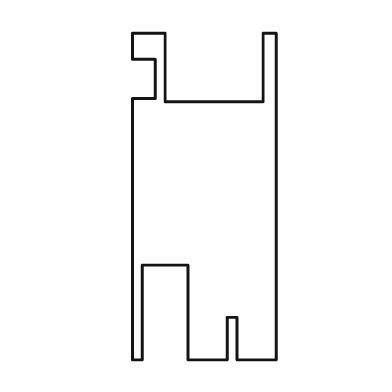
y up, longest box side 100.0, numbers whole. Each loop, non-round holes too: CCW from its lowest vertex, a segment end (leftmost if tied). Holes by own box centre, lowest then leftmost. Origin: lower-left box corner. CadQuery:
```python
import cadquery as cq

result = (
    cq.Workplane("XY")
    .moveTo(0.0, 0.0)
    .lineTo(3.0, 0.0)
    .lineTo(3.0, 29.0)
    .lineTo(17.0, 29.0)
    .lineTo(17.0, 0.0)
    .lineTo(29.0, 0.0)
    .lineTo(29.0, 13.0)
    .lineTo(32.0, 13.0)
    .lineTo(32.0, 0.0)
    .lineTo(44.0, 0.0)
    .lineTo(44.0, 100.0)
    .lineTo(40.0, 100.0)
    .lineTo(40.0, 79.0)
    .lineTo(10.0, 79.0)
    .lineTo(10.0, 100.0)
    .lineTo(0.0, 100.0)
    .lineTo(0.0, 92.0)
    .lineTo(7.0, 92.0)
    .lineTo(7.0, 80.0)
    .lineTo(0.0, 80.0)
    .close()
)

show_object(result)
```